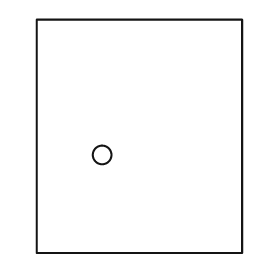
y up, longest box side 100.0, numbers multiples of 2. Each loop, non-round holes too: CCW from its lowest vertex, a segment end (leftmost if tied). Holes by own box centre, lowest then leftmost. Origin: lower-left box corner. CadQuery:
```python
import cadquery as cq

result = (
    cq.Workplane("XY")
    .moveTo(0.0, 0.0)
    .lineTo(88.0, 0.0)
    .lineTo(88.0, 100.0)
    .lineTo(0.0, 100.0)
    .close()
    .moveTo(28.0, 42.0)
    .circle(4.0)
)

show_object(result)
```